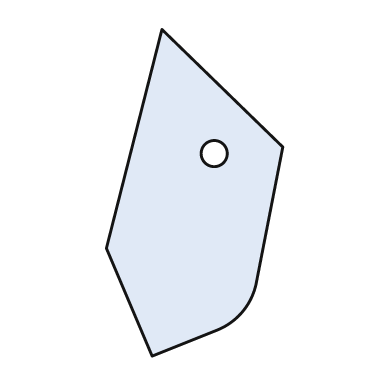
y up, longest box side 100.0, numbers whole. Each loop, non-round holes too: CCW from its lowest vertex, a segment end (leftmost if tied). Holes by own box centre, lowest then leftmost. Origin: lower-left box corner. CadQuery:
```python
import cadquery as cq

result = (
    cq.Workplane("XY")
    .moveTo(14.0, 0.0)
    .lineTo(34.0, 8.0)
    .threePointArc((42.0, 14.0), (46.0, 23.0))
    .lineTo(54.0, 64.0)
    .lineTo(17.0, 100.0)
    .lineTo(0.0, 33.0)
    .close()
    .moveTo(33.0, 62.0)
    .circle(4.0)
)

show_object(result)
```